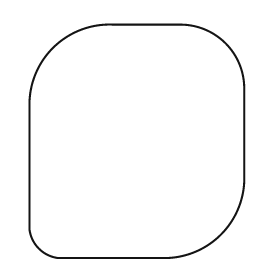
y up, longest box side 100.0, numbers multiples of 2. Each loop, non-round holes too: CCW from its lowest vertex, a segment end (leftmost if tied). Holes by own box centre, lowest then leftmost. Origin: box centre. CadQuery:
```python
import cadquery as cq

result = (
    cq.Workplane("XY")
    .moveTo(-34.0, -50.0)
    .lineTo(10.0, -50.0)
    .threePointArc((36.0, -40.0), (46.0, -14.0))
    .lineTo(46.0, 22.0)
    .threePointArc((38.0, 42.0), (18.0, 50.0))
    .lineTo(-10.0, 50.0)
    .threePointArc((-36.0, 40.0), (-46.0, 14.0))
    .lineTo(-46.0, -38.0)
    .threePointArc((-42.0, -46.0), (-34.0, -50.0))
    .close()
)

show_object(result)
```